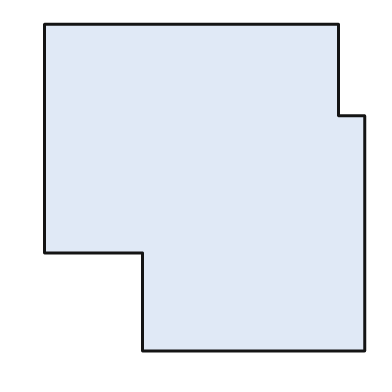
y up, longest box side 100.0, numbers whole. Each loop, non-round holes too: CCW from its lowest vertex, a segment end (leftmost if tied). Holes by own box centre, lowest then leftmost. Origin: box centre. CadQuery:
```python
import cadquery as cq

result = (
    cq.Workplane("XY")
    .moveTo(-19.0, -50.0)
    .lineTo(49.0, -50.0)
    .lineTo(49.0, 22.0)
    .lineTo(41.0, 22.0)
    .lineTo(41.0, 50.0)
    .lineTo(-49.0, 50.0)
    .lineTo(-49.0, -20.0)
    .lineTo(-19.0, -20.0)
    .close()
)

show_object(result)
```